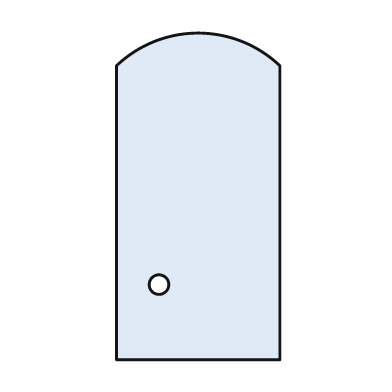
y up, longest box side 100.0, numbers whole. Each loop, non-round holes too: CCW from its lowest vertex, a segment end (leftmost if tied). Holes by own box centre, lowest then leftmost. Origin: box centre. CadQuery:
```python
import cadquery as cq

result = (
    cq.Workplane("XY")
    .moveTo(-25.0, -50.0)
    .lineTo(25.0, -50.0)
    .lineTo(25.0, 40.0)
    .threePointArc((0.0, 50.0), (-25.0, 40.0))
    .close()
    .moveTo(-12.0, -27.0)
    .circle(3.0)
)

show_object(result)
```